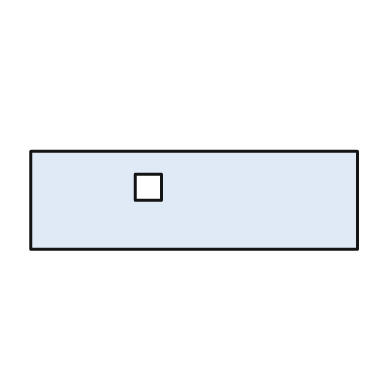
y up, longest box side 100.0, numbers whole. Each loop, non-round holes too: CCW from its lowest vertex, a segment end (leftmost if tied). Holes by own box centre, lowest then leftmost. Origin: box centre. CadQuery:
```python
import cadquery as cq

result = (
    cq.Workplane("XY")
    .moveTo(-50.0, -15.0)
    .lineTo(50.0, -15.0)
    .lineTo(50.0, 15.0)
    .lineTo(-50.0, 15.0)
    .close()
    .moveTo(-18.0, 0.0)
    .lineTo(-10.0, 0.0)
    .lineTo(-10.0, 8.0)
    .lineTo(-18.0, 8.0)
    .close()
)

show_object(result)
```